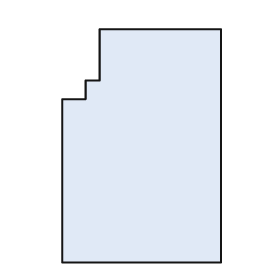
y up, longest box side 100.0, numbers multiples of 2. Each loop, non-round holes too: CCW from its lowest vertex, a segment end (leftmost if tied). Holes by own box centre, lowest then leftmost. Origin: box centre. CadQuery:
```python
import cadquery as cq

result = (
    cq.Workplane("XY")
    .moveTo(-34.0, -50.0)
    .lineTo(34.0, -50.0)
    .lineTo(34.0, 50.0)
    .lineTo(-18.0, 50.0)
    .lineTo(-18.0, 28.0)
    .lineTo(-24.0, 28.0)
    .lineTo(-24.0, 20.0)
    .lineTo(-34.0, 20.0)
    .close()
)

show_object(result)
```